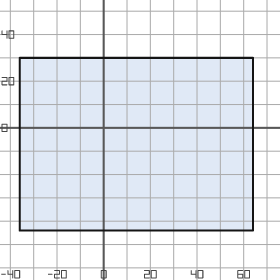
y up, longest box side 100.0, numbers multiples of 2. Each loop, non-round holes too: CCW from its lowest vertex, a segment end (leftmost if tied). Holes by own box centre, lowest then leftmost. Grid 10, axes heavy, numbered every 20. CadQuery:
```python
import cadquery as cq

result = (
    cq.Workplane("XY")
    .moveTo(-36.0, -44.0)
    .lineTo(64.0, -44.0)
    .lineTo(64.0, 30.0)
    .lineTo(-36.0, 30.0)
    .close()
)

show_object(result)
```